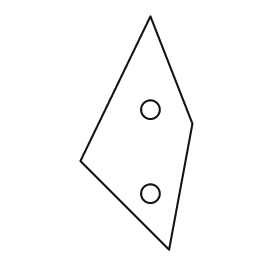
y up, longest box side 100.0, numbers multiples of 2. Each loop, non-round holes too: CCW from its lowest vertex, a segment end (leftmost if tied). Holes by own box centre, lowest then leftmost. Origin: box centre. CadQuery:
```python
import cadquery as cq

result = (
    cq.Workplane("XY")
    .moveTo(14.0, -50.0)
    .lineTo(24.0, 4.0)
    .lineTo(6.0, 50.0)
    .lineTo(-24.0, -12.0)
    .close()
    .moveTo(6.0, -26.0)
    .circle(4.0)
    .moveTo(6.0, 10.0)
    .circle(4.0)
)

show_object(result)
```